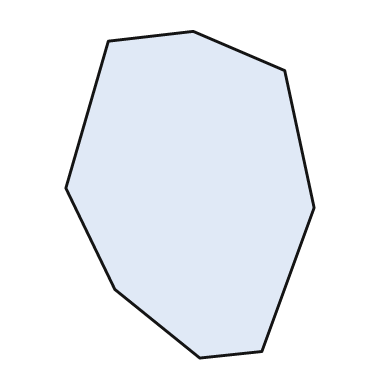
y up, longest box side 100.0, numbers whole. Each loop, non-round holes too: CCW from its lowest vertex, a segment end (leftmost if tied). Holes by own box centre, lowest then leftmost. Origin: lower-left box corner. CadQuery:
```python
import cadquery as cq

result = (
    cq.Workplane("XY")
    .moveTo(41.0, 0.0)
    .lineTo(60.0, 2.0)
    .lineTo(76.0, 46.0)
    .lineTo(67.0, 88.0)
    .lineTo(39.0, 100.0)
    .lineTo(13.0, 97.0)
    .lineTo(0.0, 52.0)
    .lineTo(15.0, 21.0)
    .close()
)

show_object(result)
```